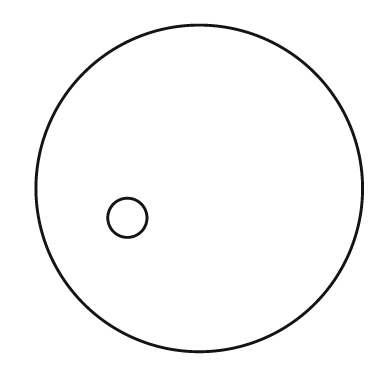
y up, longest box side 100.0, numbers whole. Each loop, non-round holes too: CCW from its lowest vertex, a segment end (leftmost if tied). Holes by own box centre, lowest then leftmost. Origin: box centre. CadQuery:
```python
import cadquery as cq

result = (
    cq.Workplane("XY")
    .moveTo(0.0, 0.0)
    .circle(50.0)
    .moveTo(-22.0, -9.0)
    .circle(6.0)
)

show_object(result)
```